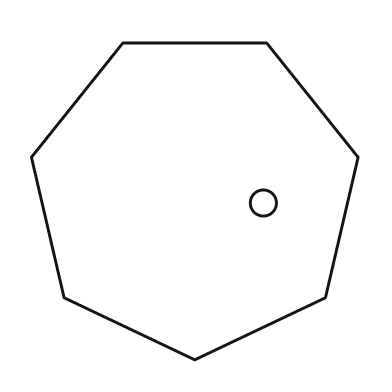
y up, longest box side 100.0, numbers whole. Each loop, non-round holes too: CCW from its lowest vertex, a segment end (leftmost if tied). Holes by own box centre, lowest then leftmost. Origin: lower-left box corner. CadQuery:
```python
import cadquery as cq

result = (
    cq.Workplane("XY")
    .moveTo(50.0, 0.0)
    .lineTo(90.0, 19.0)
    .lineTo(100.0, 62.0)
    .lineTo(72.0, 97.0)
    .lineTo(28.0, 97.0)
    .lineTo(0.0, 62.0)
    .lineTo(10.0, 19.0)
    .close()
    .moveTo(71.0, 48.0)
    .circle(4.0)
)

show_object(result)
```